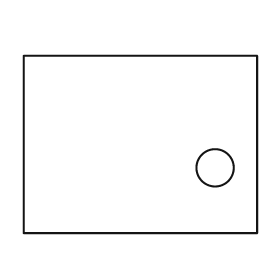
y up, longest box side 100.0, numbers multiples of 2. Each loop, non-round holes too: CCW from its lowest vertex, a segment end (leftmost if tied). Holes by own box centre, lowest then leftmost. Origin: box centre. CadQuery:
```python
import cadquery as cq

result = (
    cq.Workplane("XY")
    .moveTo(-50.0, -38.0)
    .lineTo(50.0, -38.0)
    .lineTo(50.0, 38.0)
    .lineTo(-50.0, 38.0)
    .close()
    .moveTo(32.0, -10.0)
    .circle(8.0)
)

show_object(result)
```